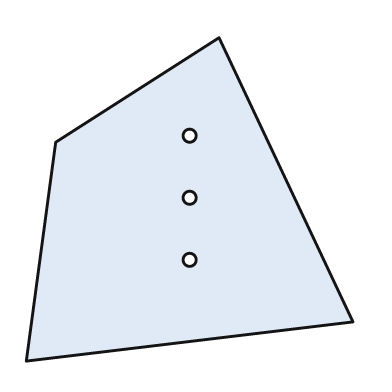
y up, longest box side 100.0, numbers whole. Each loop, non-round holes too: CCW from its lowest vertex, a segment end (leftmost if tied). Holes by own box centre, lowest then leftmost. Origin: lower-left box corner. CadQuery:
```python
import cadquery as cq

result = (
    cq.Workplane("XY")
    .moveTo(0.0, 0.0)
    .lineTo(100.0, 12.0)
    .lineTo(59.0, 99.0)
    .lineTo(9.0, 67.0)
    .close()
    .moveTo(50.0, 31.0)
    .circle(2.0)
    .moveTo(50.0, 50.0)
    .circle(2.0)
    .moveTo(50.0, 69.0)
    .circle(2.0)
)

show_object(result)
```